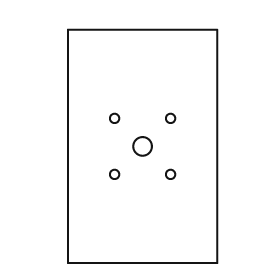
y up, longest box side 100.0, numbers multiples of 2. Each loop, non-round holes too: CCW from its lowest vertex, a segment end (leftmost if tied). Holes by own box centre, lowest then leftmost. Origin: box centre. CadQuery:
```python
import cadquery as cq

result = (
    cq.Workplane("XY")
    .moveTo(-32.0, -50.0)
    .lineTo(32.0, -50.0)
    .lineTo(32.0, 50.0)
    .lineTo(-32.0, 50.0)
    .close()
    .moveTo(-12.0, -12.0)
    .circle(2.0)
    .moveTo(12.0, -12.0)
    .circle(2.0)
    .moveTo(0.0, 0.0)
    .circle(4.0)
    .moveTo(-12.0, 12.0)
    .circle(2.0)
    .moveTo(12.0, 12.0)
    .circle(2.0)
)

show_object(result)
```